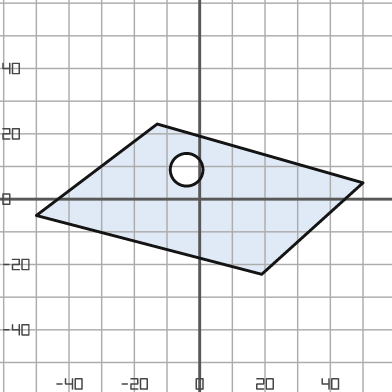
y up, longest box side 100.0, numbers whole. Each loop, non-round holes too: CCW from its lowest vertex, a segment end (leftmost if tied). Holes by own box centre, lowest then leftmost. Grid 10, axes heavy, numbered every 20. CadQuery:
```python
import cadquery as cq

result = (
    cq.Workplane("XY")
    .moveTo(19.0, -23.0)
    .lineTo(50.0, 5.0)
    .lineTo(-13.0, 23.0)
    .lineTo(-50.0, -5.0)
    .close()
    .moveTo(-4.0, 9.0)
    .circle(5.0)
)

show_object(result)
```